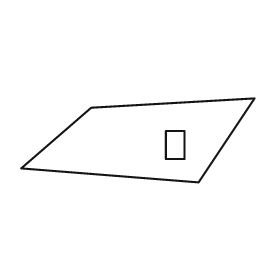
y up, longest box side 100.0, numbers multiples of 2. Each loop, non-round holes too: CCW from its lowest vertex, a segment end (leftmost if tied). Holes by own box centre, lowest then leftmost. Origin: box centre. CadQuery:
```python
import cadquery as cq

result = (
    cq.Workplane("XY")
    .moveTo(26.0, -18.0)
    .lineTo(50.0, 18.0)
    .lineTo(-20.0, 14.0)
    .lineTo(-50.0, -12.0)
    .close()
    .moveTo(12.0, -8.0)
    .lineTo(20.0, -8.0)
    .lineTo(20.0, 4.0)
    .lineTo(12.0, 4.0)
    .close()
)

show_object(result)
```